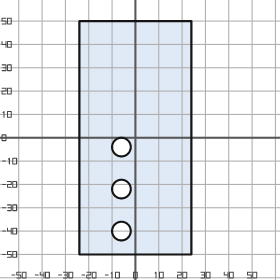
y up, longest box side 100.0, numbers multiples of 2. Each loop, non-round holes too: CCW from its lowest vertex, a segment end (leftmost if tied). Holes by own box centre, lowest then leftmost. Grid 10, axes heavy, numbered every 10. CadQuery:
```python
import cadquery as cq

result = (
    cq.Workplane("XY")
    .moveTo(-24.0, -50.0)
    .lineTo(24.0, -50.0)
    .lineTo(24.0, 50.0)
    .lineTo(-24.0, 50.0)
    .close()
    .moveTo(-6.0, -40.0)
    .circle(4.0)
    .moveTo(-6.0, -22.0)
    .circle(4.0)
    .moveTo(-6.0, -4.0)
    .circle(4.0)
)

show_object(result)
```